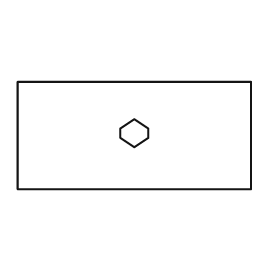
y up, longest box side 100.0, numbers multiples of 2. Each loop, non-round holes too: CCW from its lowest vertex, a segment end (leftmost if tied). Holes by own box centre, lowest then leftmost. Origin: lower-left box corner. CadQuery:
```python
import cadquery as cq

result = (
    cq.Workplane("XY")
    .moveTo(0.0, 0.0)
    .lineTo(100.0, 0.0)
    .lineTo(100.0, 46.0)
    .lineTo(0.0, 46.0)
    .close()
    .moveTo(50.0, 18.0)
    .lineTo(56.0, 22.0)
    .lineTo(56.0, 26.0)
    .lineTo(50.0, 30.0)
    .lineTo(44.0, 26.0)
    .lineTo(44.0, 22.0)
    .close()
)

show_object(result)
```